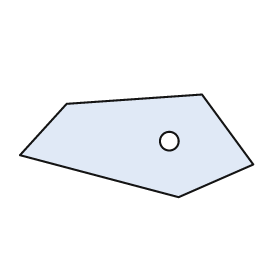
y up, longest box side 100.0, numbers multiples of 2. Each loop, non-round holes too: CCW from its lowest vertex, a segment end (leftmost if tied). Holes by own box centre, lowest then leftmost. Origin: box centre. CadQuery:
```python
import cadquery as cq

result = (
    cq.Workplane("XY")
    .moveTo(18.0, -22.0)
    .lineTo(50.0, -8.0)
    .lineTo(28.0, 22.0)
    .lineTo(-30.0, 18.0)
    .lineTo(-50.0, -4.0)
    .close()
    .moveTo(14.0, 2.0)
    .circle(4.0)
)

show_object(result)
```